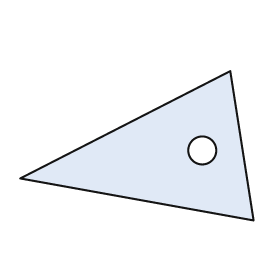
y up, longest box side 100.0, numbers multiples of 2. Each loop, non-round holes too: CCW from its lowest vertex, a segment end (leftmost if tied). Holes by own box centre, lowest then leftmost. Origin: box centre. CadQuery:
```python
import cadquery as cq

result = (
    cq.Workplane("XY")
    .moveTo(50.0, -32.0)
    .lineTo(40.0, 32.0)
    .lineTo(-50.0, -14.0)
    .close()
    .moveTo(28.0, -2.0)
    .circle(6.0)
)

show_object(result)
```